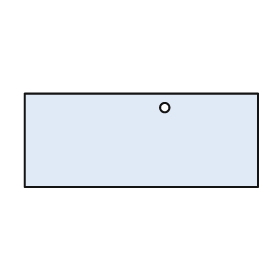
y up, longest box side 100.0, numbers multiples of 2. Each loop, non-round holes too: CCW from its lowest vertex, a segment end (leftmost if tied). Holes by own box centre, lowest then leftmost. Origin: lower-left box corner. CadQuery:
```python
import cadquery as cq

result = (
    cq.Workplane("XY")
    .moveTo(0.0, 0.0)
    .lineTo(100.0, 0.0)
    .lineTo(100.0, 40.0)
    .lineTo(0.0, 40.0)
    .close()
    .moveTo(60.0, 34.0)
    .circle(2.0)
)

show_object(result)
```